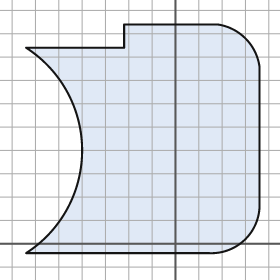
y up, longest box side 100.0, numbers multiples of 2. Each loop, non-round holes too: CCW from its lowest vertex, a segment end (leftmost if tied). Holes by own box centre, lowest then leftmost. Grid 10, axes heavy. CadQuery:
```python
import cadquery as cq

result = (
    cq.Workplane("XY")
    .moveTo(-64.0, -4.0)
    .lineTo(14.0, -4.0)
    .threePointArc((30.0, 2.0), (36.0, 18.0))
    .lineTo(36.0, 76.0)
    .threePointArc((30.0, 88.0), (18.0, 94.0))
    .lineTo(-22.0, 94.0)
    .lineTo(-22.0, 84.0)
    .lineTo(-64.0, 84.0)
    .threePointArc((-40.0, 40.0), (-64.0, -4.0))
    .close()
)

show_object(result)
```